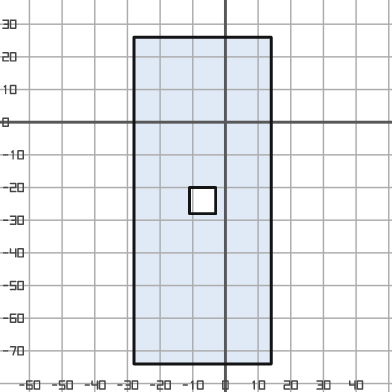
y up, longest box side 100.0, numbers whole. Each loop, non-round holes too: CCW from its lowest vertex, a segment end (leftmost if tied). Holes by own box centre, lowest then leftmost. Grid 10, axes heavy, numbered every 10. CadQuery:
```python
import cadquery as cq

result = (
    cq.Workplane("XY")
    .moveTo(-28.0, -74.0)
    .lineTo(14.0, -74.0)
    .lineTo(14.0, 26.0)
    .lineTo(-28.0, 26.0)
    .close()
    .moveTo(-11.0, -28.0)
    .lineTo(-3.0, -28.0)
    .lineTo(-3.0, -20.0)
    .lineTo(-11.0, -20.0)
    .close()
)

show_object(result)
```